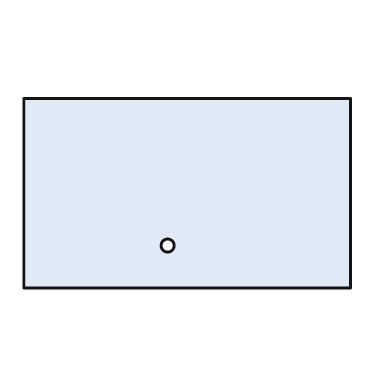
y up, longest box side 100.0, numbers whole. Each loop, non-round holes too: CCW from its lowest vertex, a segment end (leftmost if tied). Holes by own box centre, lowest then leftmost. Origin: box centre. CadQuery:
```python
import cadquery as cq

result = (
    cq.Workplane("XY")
    .moveTo(-50.0, -29.0)
    .lineTo(50.0, -29.0)
    .lineTo(50.0, 29.0)
    .lineTo(-50.0, 29.0)
    .close()
    .moveTo(-6.0, -16.0)
    .circle(2.0)
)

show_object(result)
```